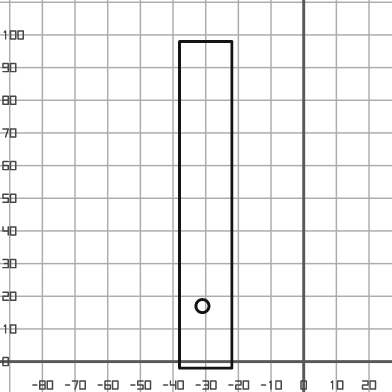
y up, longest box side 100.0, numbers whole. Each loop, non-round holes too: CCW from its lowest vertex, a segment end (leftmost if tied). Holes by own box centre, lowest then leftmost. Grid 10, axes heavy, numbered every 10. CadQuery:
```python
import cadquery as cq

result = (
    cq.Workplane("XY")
    .moveTo(-38.0, -2.0)
    .lineTo(-22.0, -2.0)
    .lineTo(-22.0, 98.0)
    .lineTo(-38.0, 98.0)
    .close()
    .moveTo(-31.0, 17.0)
    .circle(2.0)
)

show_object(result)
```